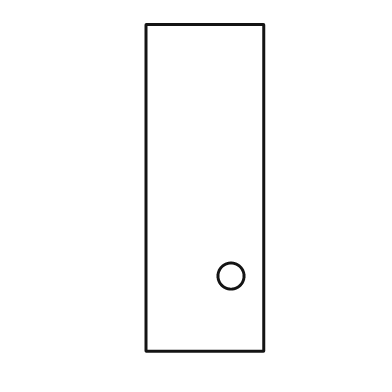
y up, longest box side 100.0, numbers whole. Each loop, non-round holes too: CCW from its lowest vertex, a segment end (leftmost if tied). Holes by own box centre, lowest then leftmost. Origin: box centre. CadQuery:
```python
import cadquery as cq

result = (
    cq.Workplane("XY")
    .moveTo(-18.0, -50.0)
    .lineTo(18.0, -50.0)
    .lineTo(18.0, 50.0)
    .lineTo(-18.0, 50.0)
    .close()
    .moveTo(8.0, -27.0)
    .circle(4.0)
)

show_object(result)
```